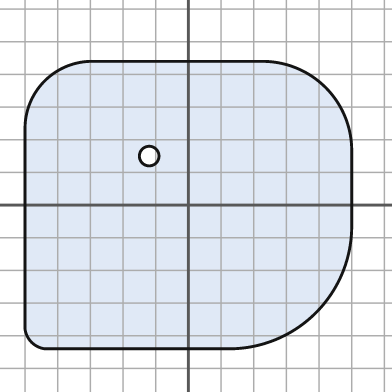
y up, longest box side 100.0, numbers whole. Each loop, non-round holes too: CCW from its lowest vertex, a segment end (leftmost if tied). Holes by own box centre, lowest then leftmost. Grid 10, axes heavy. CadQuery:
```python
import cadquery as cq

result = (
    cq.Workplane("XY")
    .moveTo(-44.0, -44.0)
    .lineTo(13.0, -44.0)
    .threePointArc((39.0, -33.0), (50.0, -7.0))
    .lineTo(50.0, 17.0)
    .threePointArc((42.0, 36.0), (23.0, 44.0))
    .lineTo(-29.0, 44.0)
    .threePointArc((-44.0, 38.0), (-50.0, 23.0))
    .lineTo(-50.0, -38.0)
    .threePointArc((-48.0, -42.0), (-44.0, -44.0))
    .close()
    .moveTo(-12.0, 15.0)
    .circle(3.0)
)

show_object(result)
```